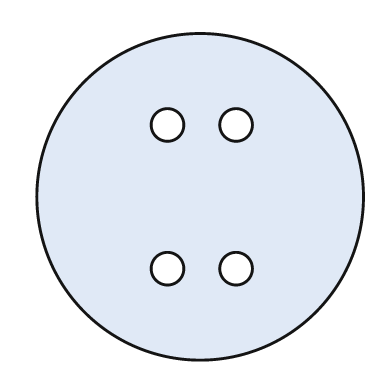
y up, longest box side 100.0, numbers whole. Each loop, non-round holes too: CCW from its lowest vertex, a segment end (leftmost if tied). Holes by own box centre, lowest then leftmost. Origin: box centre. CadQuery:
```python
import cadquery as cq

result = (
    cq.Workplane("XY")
    .moveTo(0.0, 0.0)
    .circle(50.0)
    .moveTo(-10.0, -22.0)
    .circle(5.0)
    .moveTo(11.0, -22.0)
    .circle(5.0)
    .moveTo(-10.0, 22.0)
    .circle(5.0)
    .moveTo(11.0, 22.0)
    .circle(5.0)
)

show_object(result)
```